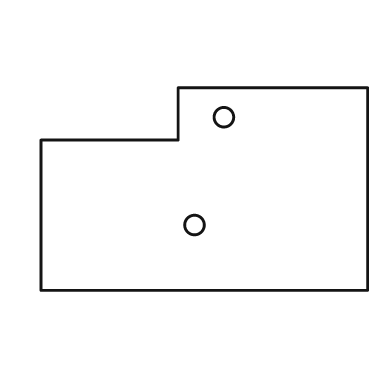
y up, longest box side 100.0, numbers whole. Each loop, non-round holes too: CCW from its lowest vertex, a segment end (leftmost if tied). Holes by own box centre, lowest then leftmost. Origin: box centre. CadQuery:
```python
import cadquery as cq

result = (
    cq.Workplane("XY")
    .moveTo(-50.0, -31.0)
    .lineTo(50.0, -31.0)
    .lineTo(50.0, 31.0)
    .lineTo(-8.0, 31.0)
    .lineTo(-8.0, 15.0)
    .lineTo(-50.0, 15.0)
    .close()
    .moveTo(-3.0, -11.0)
    .circle(3.0)
    .moveTo(6.0, 22.0)
    .circle(3.0)
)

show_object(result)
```